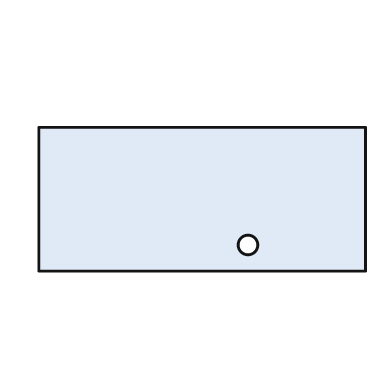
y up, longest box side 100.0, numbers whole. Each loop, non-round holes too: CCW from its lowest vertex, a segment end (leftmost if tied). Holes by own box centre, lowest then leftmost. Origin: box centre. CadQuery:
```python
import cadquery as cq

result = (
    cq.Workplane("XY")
    .moveTo(-50.0, -22.0)
    .lineTo(50.0, -22.0)
    .lineTo(50.0, 22.0)
    .lineTo(-50.0, 22.0)
    .close()
    .moveTo(14.0, -14.0)
    .circle(3.0)
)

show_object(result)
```